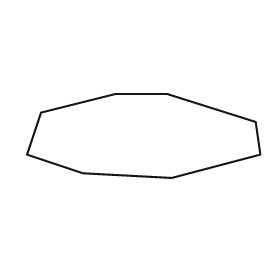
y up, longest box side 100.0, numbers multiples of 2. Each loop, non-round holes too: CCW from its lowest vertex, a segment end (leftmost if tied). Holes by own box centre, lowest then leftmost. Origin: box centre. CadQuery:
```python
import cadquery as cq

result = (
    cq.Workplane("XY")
    .moveTo(12.0, -18.0)
    .lineTo(50.0, -8.0)
    .lineTo(48.0, 6.0)
    .lineTo(10.0, 18.0)
    .lineTo(-12.0, 18.0)
    .lineTo(-44.0, 10.0)
    .lineTo(-50.0, -8.0)
    .lineTo(-26.0, -16.0)
    .close()
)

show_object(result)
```